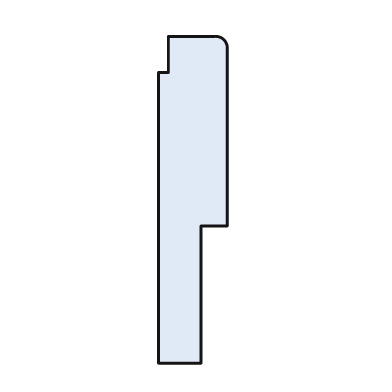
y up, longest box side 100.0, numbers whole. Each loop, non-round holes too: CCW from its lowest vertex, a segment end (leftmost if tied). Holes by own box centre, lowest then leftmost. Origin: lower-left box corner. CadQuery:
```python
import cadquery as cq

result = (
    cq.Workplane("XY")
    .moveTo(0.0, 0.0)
    .lineTo(13.0, 0.0)
    .lineTo(13.0, 42.0)
    .lineTo(21.0, 42.0)
    .lineTo(21.0, 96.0)
    .threePointArc((20.0, 99.0), (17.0, 100.0))
    .lineTo(3.0, 100.0)
    .lineTo(3.0, 89.0)
    .lineTo(0.0, 89.0)
    .close()
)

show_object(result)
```